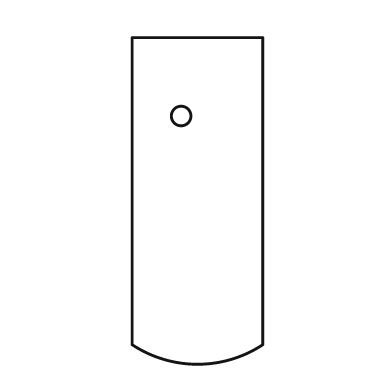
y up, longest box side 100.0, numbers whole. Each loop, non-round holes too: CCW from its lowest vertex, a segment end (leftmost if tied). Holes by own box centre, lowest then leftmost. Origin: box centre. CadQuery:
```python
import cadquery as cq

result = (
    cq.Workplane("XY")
    .moveTo(-20.0, -44.0)
    .threePointArc((0.0, -50.0), (20.0, -44.0))
    .lineTo(20.0, 50.0)
    .lineTo(-20.0, 50.0)
    .close()
    .moveTo(-5.0, 26.0)
    .circle(3.0)
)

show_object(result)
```